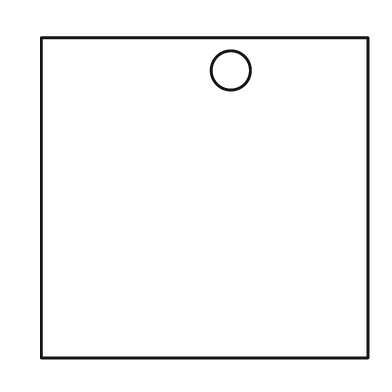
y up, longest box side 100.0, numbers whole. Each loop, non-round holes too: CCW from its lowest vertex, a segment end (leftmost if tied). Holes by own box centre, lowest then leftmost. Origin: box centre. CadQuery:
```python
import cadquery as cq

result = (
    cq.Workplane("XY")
    .moveTo(-50.0, -49.0)
    .lineTo(50.0, -49.0)
    .lineTo(50.0, 49.0)
    .lineTo(-50.0, 49.0)
    .close()
    .moveTo(8.0, 39.0)
    .circle(6.0)
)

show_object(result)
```